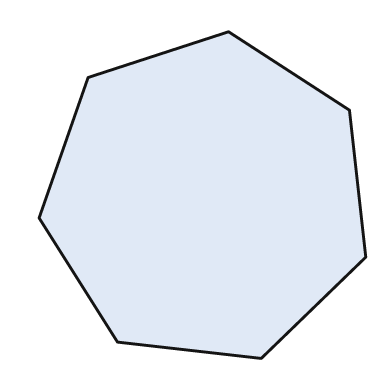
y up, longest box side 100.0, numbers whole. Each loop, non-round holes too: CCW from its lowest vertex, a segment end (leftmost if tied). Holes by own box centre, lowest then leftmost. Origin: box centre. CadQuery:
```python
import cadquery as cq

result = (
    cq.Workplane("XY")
    .moveTo(18.0, -50.0)
    .lineTo(50.0, -19.0)
    .lineTo(45.0, 26.0)
    .lineTo(8.0, 50.0)
    .lineTo(-35.0, 36.0)
    .lineTo(-50.0, -7.0)
    .lineTo(-26.0, -45.0)
    .close()
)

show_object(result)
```